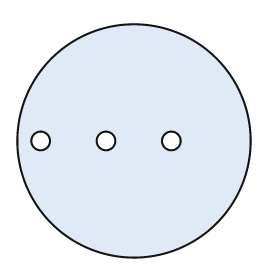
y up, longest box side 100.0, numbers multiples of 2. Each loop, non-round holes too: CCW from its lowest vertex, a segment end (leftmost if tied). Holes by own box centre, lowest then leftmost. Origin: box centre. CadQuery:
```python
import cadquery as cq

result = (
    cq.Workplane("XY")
    .moveTo(0.0, 0.0)
    .circle(50.0)
    .moveTo(-40.0, 0.0)
    .circle(4.0)
    .moveTo(-12.0, 0.0)
    .circle(4.0)
    .moveTo(16.0, 0.0)
    .circle(4.0)
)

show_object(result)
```